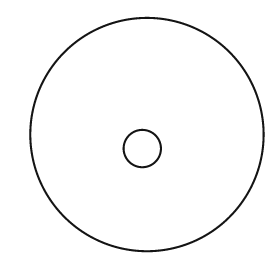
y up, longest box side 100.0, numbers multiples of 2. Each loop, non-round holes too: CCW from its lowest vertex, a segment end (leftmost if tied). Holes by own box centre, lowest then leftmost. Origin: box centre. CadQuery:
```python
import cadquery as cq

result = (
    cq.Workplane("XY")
    .moveTo(0.0, 0.0)
    .circle(50.0)
    .moveTo(-2.0, -6.0)
    .circle(8.0)
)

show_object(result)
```